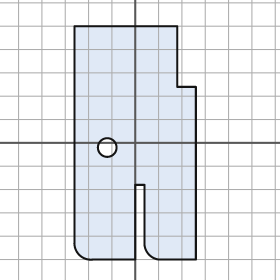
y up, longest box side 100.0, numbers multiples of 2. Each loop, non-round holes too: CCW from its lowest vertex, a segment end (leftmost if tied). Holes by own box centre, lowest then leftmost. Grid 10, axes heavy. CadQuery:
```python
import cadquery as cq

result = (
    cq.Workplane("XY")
    .moveTo(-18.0, -50.0)
    .lineTo(0.0, -50.0)
    .lineTo(0.0, -18.0)
    .lineTo(4.0, -18.0)
    .lineTo(4.0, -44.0)
    .threePointArc((6.0, -48.0), (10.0, -50.0))
    .lineTo(26.0, -50.0)
    .lineTo(26.0, 24.0)
    .lineTo(18.0, 24.0)
    .lineTo(18.0, 50.0)
    .lineTo(-26.0, 50.0)
    .lineTo(-26.0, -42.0)
    .threePointArc((-24.0, -48.0), (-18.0, -50.0))
    .close()
    .moveTo(-12.0, -2.0)
    .circle(4.0)
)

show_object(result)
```